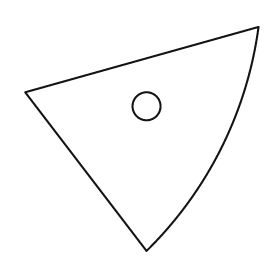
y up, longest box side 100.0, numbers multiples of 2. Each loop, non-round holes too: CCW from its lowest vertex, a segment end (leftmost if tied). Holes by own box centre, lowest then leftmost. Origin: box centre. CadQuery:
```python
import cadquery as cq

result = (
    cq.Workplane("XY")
    .moveTo(2.0, -48.0)
    .threePointArc((34.0, -4.0), (50.0, 48.0))
    .lineTo(-50.0, 20.0)
    .close()
    .moveTo(2.0, 14.0)
    .circle(6.0)
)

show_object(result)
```